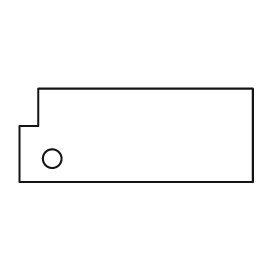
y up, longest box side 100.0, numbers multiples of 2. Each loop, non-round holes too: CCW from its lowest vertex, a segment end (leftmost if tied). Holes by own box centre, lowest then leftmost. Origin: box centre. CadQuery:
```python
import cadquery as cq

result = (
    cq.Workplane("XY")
    .moveTo(-50.0, -20.0)
    .lineTo(50.0, -20.0)
    .lineTo(50.0, 20.0)
    .lineTo(-42.0, 20.0)
    .lineTo(-42.0, 4.0)
    .lineTo(-50.0, 4.0)
    .close()
    .moveTo(-36.0, -10.0)
    .circle(4.0)
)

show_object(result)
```